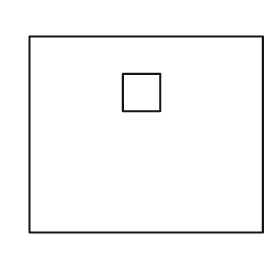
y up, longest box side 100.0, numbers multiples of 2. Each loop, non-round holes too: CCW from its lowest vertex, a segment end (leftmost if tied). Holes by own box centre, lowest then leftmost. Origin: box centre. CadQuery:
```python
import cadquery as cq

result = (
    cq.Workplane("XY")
    .moveTo(-50.0, -42.0)
    .lineTo(50.0, -42.0)
    .lineTo(50.0, 42.0)
    .lineTo(-50.0, 42.0)
    .close()
    .moveTo(-10.0, 10.0)
    .lineTo(6.0, 10.0)
    .lineTo(6.0, 26.0)
    .lineTo(-10.0, 26.0)
    .close()
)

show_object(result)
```